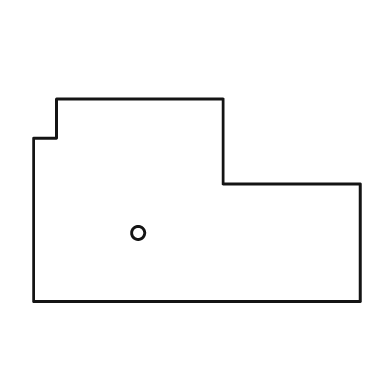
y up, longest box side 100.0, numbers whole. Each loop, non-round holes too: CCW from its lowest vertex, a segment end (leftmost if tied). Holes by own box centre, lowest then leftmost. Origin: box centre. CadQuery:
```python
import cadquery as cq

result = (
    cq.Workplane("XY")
    .moveTo(-50.0, -31.0)
    .lineTo(50.0, -31.0)
    .lineTo(50.0, 5.0)
    .lineTo(8.0, 5.0)
    .lineTo(8.0, 31.0)
    .lineTo(-43.0, 31.0)
    .lineTo(-43.0, 19.0)
    .lineTo(-50.0, 19.0)
    .close()
    .moveTo(-18.0, -10.0)
    .circle(2.0)
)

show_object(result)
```